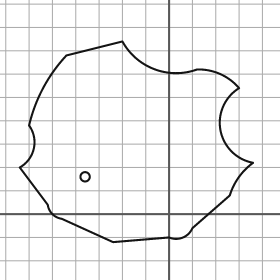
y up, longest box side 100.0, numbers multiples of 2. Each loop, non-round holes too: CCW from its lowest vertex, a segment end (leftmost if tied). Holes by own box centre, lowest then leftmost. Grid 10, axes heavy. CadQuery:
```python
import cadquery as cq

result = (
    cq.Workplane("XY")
    .moveTo(-24.0, -12.0)
    .lineTo(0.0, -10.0)
    .threePointArc((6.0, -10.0), (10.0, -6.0))
    .lineTo(26.0, 8.0)
    .threePointArc((30.0, 16.0), (36.0, 22.0))
    .threePointArc((22.0, 36.0), (30.0, 54.0))
    .threePointArc((22.0, 60.0), (12.0, 62.0))
    .threePointArc((-6.0, 62.0), (-20.0, 74.0))
    .lineTo(-44.0, 68.0)
    .threePointArc((-54.0, 54.0), (-60.0, 38.0))
    .threePointArc((-58.0, 28.0), (-64.0, 20.0))
    .lineTo(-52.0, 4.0)
    .threePointArc((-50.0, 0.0), (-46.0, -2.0))
    .close()
    .moveTo(-36.0, 16.0)
    .circle(2.0)
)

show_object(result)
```